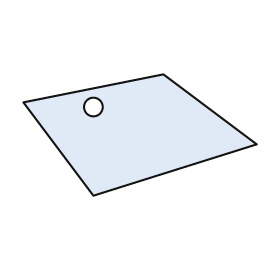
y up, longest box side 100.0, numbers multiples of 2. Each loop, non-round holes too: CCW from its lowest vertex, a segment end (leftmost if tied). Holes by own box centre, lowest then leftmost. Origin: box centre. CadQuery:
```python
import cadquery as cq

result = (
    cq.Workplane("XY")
    .moveTo(-20.0, -26.0)
    .lineTo(50.0, -4.0)
    .lineTo(10.0, 26.0)
    .lineTo(-50.0, 14.0)
    .close()
    .moveTo(-20.0, 12.0)
    .circle(4.0)
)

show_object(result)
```